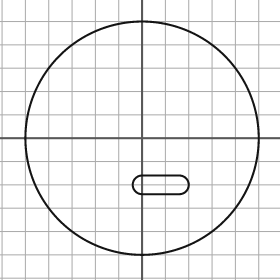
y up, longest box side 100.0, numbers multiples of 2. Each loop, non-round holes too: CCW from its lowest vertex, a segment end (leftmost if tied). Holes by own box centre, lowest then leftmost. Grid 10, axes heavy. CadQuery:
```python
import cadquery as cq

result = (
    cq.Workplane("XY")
    .moveTo(0.0, 0.0)
    .circle(50.0)
    .moveTo(0.0, -24.0)
    .lineTo(16.0, -24.0)
    .threePointArc((20.0, -20.0), (16.0, -16.0))
    .lineTo(0.0, -16.0)
    .threePointArc((-4.0, -20.0), (0.0, -24.0))
    .close()
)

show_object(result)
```